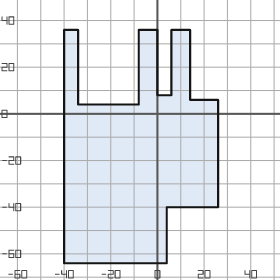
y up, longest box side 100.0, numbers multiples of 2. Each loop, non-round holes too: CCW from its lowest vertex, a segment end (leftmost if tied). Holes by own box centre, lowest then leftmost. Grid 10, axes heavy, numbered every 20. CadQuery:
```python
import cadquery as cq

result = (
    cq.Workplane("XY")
    .moveTo(-40.0, -64.0)
    .lineTo(4.0, -64.0)
    .lineTo(4.0, -40.0)
    .lineTo(26.0, -40.0)
    .lineTo(26.0, 6.0)
    .lineTo(14.0, 6.0)
    .lineTo(14.0, 36.0)
    .lineTo(6.0, 36.0)
    .lineTo(6.0, 8.0)
    .lineTo(0.0, 8.0)
    .lineTo(0.0, 36.0)
    .lineTo(-8.0, 36.0)
    .lineTo(-8.0, 4.0)
    .lineTo(-34.0, 4.0)
    .lineTo(-34.0, 36.0)
    .lineTo(-40.0, 36.0)
    .close()
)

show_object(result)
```